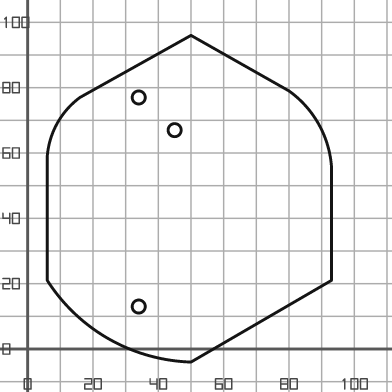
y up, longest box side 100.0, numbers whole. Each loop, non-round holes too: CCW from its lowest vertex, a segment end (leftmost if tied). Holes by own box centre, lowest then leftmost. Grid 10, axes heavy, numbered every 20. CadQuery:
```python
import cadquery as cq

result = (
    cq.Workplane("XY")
    .moveTo(50.0, -4.0)
    .lineTo(93.0, 21.0)
    .lineTo(93.0, 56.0)
    .threePointArc((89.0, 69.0), (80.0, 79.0))
    .lineTo(50.0, 96.0)
    .lineTo(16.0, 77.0)
    .threePointArc((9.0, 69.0), (6.0, 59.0))
    .lineTo(6.0, 21.0)
    .threePointArc((25.0, 3.0), (50.0, -4.0))
    .close()
    .moveTo(34.0, 13.0)
    .circle(2.0)
    .moveTo(45.0, 67.0)
    .circle(2.0)
    .moveTo(34.0, 77.0)
    .circle(2.0)
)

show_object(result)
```